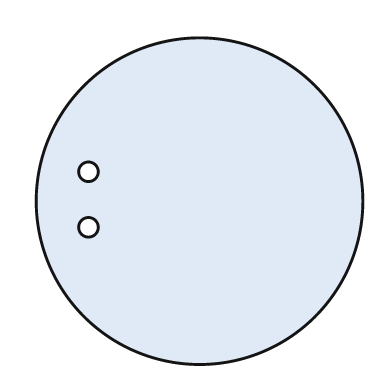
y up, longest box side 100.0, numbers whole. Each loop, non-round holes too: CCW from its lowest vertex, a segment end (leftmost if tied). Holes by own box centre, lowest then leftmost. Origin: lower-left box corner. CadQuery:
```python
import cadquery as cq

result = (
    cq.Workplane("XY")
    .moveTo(50.0, 50.0)
    .circle(50.0)
    .moveTo(16.0, 42.0)
    .circle(3.0)
    .moveTo(16.0, 59.0)
    .circle(3.0)
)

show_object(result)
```